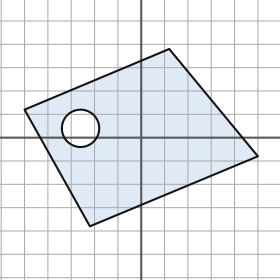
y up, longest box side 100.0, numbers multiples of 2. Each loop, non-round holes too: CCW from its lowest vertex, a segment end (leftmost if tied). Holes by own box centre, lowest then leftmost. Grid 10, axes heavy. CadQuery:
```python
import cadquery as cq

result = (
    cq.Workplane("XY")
    .moveTo(-22.0, -38.0)
    .lineTo(50.0, -8.0)
    .lineTo(12.0, 38.0)
    .lineTo(-50.0, 12.0)
    .close()
    .moveTo(-26.0, 4.0)
    .circle(8.0)
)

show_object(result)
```